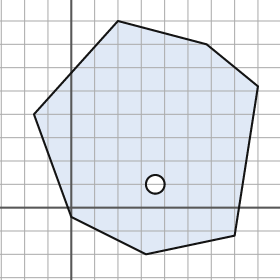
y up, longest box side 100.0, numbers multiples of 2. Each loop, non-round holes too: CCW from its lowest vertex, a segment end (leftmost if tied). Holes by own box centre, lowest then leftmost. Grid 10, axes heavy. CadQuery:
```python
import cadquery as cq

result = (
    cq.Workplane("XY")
    .moveTo(32.0, -20.0)
    .lineTo(70.0, -12.0)
    .lineTo(80.0, 52.0)
    .lineTo(58.0, 70.0)
    .lineTo(20.0, 80.0)
    .lineTo(-16.0, 40.0)
    .lineTo(0.0, -4.0)
    .close()
    .moveTo(36.0, 10.0)
    .circle(4.0)
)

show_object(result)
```